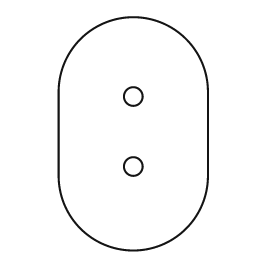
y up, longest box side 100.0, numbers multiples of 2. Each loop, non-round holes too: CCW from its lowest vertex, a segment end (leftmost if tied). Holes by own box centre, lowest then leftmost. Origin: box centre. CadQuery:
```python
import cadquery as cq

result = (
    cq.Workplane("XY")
    .moveTo(-32.0, -18.0)
    .threePointArc((0.0, -50.0), (32.0, -18.0))
    .lineTo(32.0, 18.0)
    .threePointArc((0.0, 50.0), (-32.0, 18.0))
    .close()
    .moveTo(0.0, -14.0)
    .circle(4.0)
    .moveTo(0.0, 16.0)
    .circle(4.0)
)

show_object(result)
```